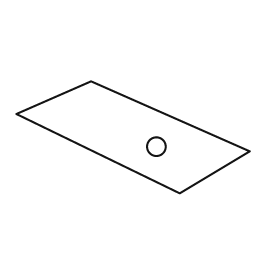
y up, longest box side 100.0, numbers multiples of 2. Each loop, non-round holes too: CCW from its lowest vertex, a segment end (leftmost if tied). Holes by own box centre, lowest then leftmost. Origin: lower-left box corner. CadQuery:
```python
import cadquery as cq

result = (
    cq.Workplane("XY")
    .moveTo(70.0, 0.0)
    .lineTo(100.0, 18.0)
    .lineTo(32.0, 48.0)
    .lineTo(0.0, 34.0)
    .close()
    .moveTo(60.0, 20.0)
    .circle(4.0)
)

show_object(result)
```